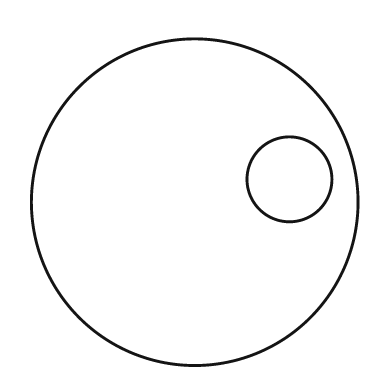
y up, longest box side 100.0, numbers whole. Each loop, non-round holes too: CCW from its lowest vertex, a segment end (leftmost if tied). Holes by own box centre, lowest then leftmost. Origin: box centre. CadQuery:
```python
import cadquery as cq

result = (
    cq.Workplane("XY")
    .moveTo(0.0, 0.0)
    .circle(50.0)
    .moveTo(29.0, 7.0)
    .circle(13.0)
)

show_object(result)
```